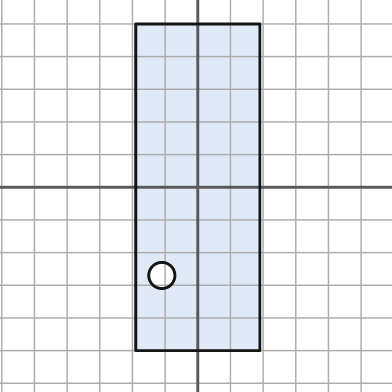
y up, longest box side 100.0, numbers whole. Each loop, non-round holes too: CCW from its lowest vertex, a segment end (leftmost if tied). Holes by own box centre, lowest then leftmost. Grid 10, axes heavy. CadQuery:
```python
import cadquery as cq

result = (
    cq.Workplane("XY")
    .moveTo(-19.0, -50.0)
    .lineTo(19.0, -50.0)
    .lineTo(19.0, 50.0)
    .lineTo(-19.0, 50.0)
    .close()
    .moveTo(-11.0, -27.0)
    .circle(4.0)
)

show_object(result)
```